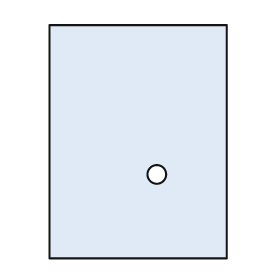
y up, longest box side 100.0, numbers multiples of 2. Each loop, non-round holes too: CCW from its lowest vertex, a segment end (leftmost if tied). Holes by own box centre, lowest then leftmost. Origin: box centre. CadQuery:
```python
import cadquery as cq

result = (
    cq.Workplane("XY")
    .moveTo(-38.0, -50.0)
    .lineTo(38.0, -50.0)
    .lineTo(38.0, 50.0)
    .lineTo(-38.0, 50.0)
    .close()
    .moveTo(8.0, -14.0)
    .circle(4.0)
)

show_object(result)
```